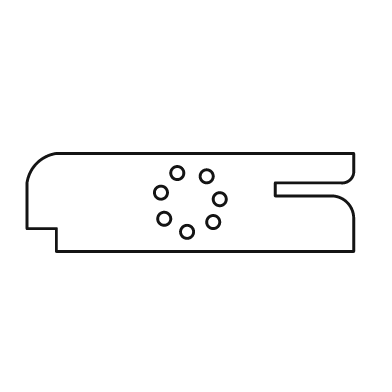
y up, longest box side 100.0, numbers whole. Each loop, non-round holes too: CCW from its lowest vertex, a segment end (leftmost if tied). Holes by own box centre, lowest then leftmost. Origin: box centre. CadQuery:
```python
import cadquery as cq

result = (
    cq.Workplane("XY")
    .moveTo(-41.0, -15.0)
    .lineTo(50.0, -15.0)
    .lineTo(50.0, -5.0)
    .threePointArc((48.0, 0.0), (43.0, 2.0))
    .lineTo(26.0, 2.0)
    .lineTo(26.0, 6.0)
    .lineTo(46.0, 6.0)
    .threePointArc((49.0, 7.0), (50.0, 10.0))
    .lineTo(50.0, 15.0)
    .lineTo(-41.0, 15.0)
    .threePointArc((-47.0, 12.0), (-50.0, 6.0))
    .lineTo(-50.0, -8.0)
    .lineTo(-41.0, -8.0)
    .close()
    .moveTo(-1.0, -9.0)
    .circle(2.0)
    .moveTo(7.0, -6.0)
    .circle(2.0)
    .moveTo(-8.0, -5.0)
    .circle(2.0)
    .moveTo(9.0, 1.0)
    .circle(2.0)
    .moveTo(-9.0, 3.0)
    .circle(2.0)
    .moveTo(5.0, 8.0)
    .circle(2.0)
    .moveTo(-4.0, 9.0)
    .circle(2.0)
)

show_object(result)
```